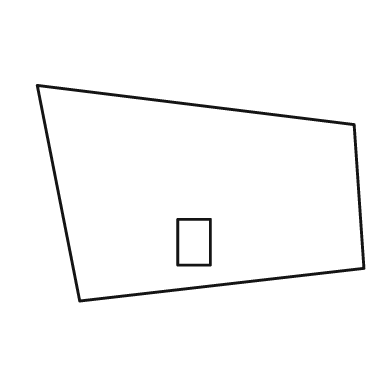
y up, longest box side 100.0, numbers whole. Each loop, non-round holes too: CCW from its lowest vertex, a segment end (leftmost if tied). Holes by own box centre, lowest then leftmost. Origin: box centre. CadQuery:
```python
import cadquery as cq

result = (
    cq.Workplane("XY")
    .moveTo(-37.0, -33.0)
    .lineTo(50.0, -23.0)
    .lineTo(47.0, 21.0)
    .lineTo(-50.0, 33.0)
    .close()
    .moveTo(-7.0, -22.0)
    .lineTo(3.0, -22.0)
    .lineTo(3.0, -8.0)
    .lineTo(-7.0, -8.0)
    .close()
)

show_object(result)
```